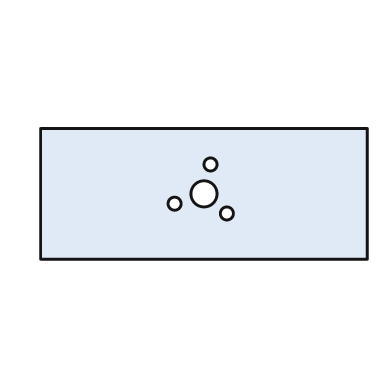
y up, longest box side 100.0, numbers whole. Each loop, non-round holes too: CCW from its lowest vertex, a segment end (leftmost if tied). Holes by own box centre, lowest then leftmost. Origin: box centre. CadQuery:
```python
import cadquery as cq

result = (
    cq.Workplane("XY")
    .moveTo(-50.0, -20.0)
    .lineTo(50.0, -20.0)
    .lineTo(50.0, 20.0)
    .lineTo(-50.0, 20.0)
    .close()
    .moveTo(7.0, -6.0)
    .circle(2.0)
    .moveTo(-9.0, -3.0)
    .circle(2.0)
    .moveTo(0.0, 0.0)
    .circle(4.0)
    .moveTo(2.0, 9.0)
    .circle(2.0)
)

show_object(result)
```